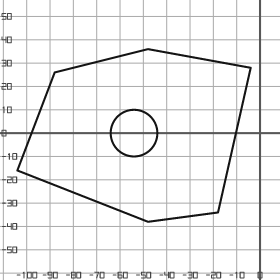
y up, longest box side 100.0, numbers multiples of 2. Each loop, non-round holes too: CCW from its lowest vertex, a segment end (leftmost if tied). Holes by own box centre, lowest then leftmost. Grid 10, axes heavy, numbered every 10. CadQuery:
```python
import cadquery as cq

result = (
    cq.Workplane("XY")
    .moveTo(-48.0, -38.0)
    .lineTo(-18.0, -34.0)
    .lineTo(-4.0, 28.0)
    .lineTo(-48.0, 36.0)
    .lineTo(-88.0, 26.0)
    .lineTo(-104.0, -16.0)
    .close()
    .moveTo(-54.0, 0.0)
    .circle(10.0)
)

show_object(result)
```